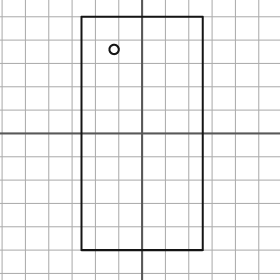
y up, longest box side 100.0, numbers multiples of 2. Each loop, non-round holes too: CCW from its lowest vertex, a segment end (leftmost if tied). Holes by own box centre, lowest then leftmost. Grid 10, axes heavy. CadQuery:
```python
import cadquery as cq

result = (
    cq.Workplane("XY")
    .moveTo(-26.0, -50.0)
    .lineTo(26.0, -50.0)
    .lineTo(26.0, 50.0)
    .lineTo(-26.0, 50.0)
    .close()
    .moveTo(-12.0, 36.0)
    .circle(2.0)
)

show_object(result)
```